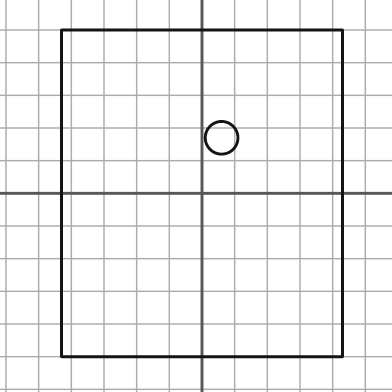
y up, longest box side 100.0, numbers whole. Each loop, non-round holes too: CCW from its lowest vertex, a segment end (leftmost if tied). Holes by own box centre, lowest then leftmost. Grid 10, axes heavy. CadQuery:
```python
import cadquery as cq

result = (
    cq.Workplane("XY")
    .moveTo(-43.0, -50.0)
    .lineTo(43.0, -50.0)
    .lineTo(43.0, 50.0)
    .lineTo(-43.0, 50.0)
    .close()
    .moveTo(6.0, 17.0)
    .circle(5.0)
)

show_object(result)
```